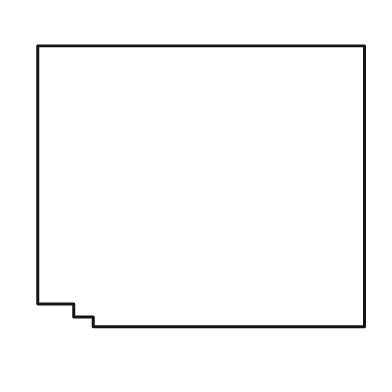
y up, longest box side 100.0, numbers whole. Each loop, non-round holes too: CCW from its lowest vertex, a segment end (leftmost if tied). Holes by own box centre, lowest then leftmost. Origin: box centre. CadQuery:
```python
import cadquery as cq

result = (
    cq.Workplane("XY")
    .moveTo(-33.0, -43.0)
    .lineTo(50.0, -43.0)
    .lineTo(50.0, 43.0)
    .lineTo(-50.0, 43.0)
    .lineTo(-50.0, -36.0)
    .lineTo(-39.0, -36.0)
    .lineTo(-39.0, -40.0)
    .lineTo(-33.0, -40.0)
    .close()
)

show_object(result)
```